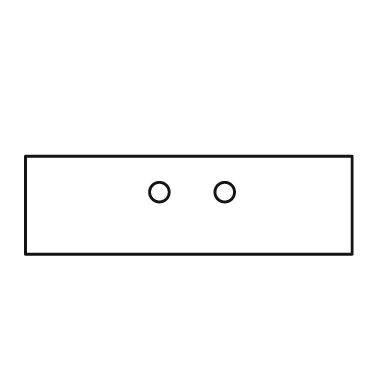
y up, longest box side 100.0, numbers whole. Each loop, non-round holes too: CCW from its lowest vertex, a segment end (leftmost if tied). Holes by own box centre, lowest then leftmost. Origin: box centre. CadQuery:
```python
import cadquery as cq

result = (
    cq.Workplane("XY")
    .moveTo(-50.0, -15.0)
    .lineTo(50.0, -15.0)
    .lineTo(50.0, 15.0)
    .lineTo(-50.0, 15.0)
    .close()
    .moveTo(-9.0, 4.0)
    .circle(3.0)
    .moveTo(11.0, 4.0)
    .circle(3.0)
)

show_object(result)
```